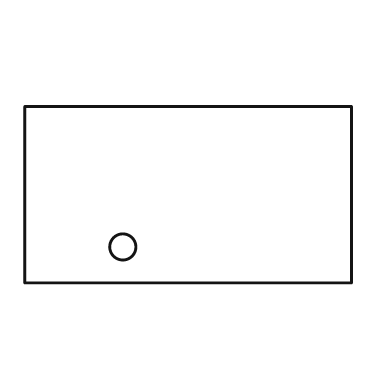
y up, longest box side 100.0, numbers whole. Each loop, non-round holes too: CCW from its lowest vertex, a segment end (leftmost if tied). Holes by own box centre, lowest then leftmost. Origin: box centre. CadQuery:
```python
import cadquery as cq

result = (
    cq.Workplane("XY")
    .moveTo(-50.0, -27.0)
    .lineTo(50.0, -27.0)
    .lineTo(50.0, 27.0)
    .lineTo(-50.0, 27.0)
    .close()
    .moveTo(-20.0, -16.0)
    .circle(4.0)
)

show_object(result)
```